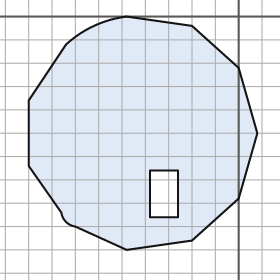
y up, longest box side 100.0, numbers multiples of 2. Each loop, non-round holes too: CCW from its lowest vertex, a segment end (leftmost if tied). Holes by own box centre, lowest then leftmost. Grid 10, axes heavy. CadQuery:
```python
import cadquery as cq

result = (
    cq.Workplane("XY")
    .moveTo(-48.0, -100.0)
    .lineTo(-20.0, -96.0)
    .lineTo(0.0, -78.0)
    .lineTo(8.0, -50.0)
    .lineTo(0.0, -22.0)
    .lineTo(-20.0, -4.0)
    .lineTo(-48.0, 0.0)
    .threePointArc((-62.0, -4.0), (-74.0, -12.0))
    .lineTo(-90.0, -36.0)
    .lineTo(-90.0, -64.0)
    .lineTo(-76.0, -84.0)
    .threePointArc((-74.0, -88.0), (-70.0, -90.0))
    .close()
    .moveTo(-38.0, -86.0)
    .lineTo(-26.0, -86.0)
    .lineTo(-26.0, -66.0)
    .lineTo(-38.0, -66.0)
    .close()
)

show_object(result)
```